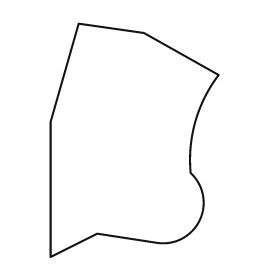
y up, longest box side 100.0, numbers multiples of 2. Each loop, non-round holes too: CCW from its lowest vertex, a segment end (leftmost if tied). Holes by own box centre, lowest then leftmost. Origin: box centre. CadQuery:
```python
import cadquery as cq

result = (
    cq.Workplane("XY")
    .moveTo(-36.0, -50.0)
    .lineTo(-16.0, -40.0)
    .lineTo(10.0, -44.0)
    .threePointArc((28.0, -34.0), (24.0, -14.0))
    .threePointArc((26.0, 8.0), (36.0, 28.0))
    .lineTo(4.0, 46.0)
    .lineTo(-24.0, 50.0)
    .lineTo(-36.0, 8.0)
    .close()
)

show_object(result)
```